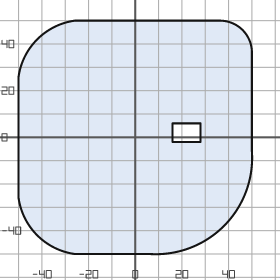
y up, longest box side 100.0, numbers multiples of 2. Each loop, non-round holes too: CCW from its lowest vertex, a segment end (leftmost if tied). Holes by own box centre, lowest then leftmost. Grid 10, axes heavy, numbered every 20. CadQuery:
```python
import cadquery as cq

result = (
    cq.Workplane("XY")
    .moveTo(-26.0, -50.0)
    .lineTo(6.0, -50.0)
    .threePointArc((38.0, -38.0), (50.0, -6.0))
    .lineTo(50.0, 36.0)
    .threePointArc((46.0, 46.0), (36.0, 50.0))
    .lineTo(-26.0, 50.0)
    .threePointArc((-42.0, 42.0), (-50.0, 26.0))
    .lineTo(-50.0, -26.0)
    .threePointArc((-42.0, -42.0), (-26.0, -50.0))
    .close()
    .moveTo(16.0, -2.0)
    .lineTo(28.0, -2.0)
    .lineTo(28.0, 6.0)
    .lineTo(16.0, 6.0)
    .close()
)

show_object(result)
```